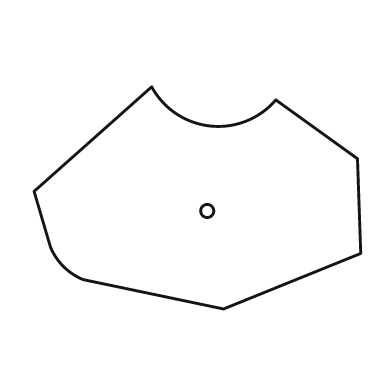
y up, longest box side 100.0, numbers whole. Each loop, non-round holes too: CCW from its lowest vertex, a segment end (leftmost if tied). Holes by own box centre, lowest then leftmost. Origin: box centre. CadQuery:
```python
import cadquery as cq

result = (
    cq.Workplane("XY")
    .moveTo(8.0, -34.0)
    .lineTo(50.0, -17.0)
    .lineTo(49.0, 12.0)
    .lineTo(24.0, 30.0)
    .threePointArc((4.0, 22.0), (-14.0, 34.0))
    .lineTo(-50.0, 2.0)
    .lineTo(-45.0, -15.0)
    .threePointArc((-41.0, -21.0), (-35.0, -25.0))
    .close()
    .moveTo(3.0, -4.0)
    .circle(2.0)
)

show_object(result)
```